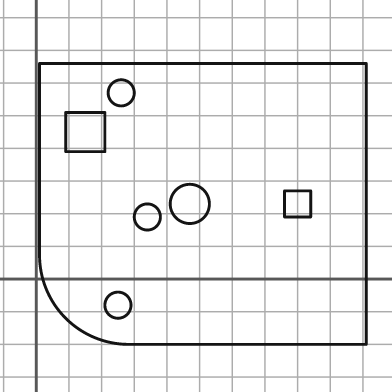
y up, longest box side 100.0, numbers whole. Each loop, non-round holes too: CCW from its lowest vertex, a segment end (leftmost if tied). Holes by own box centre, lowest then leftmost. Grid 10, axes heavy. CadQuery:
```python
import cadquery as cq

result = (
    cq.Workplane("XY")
    .moveTo(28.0, -20.0)
    .lineTo(101.0, -20.0)
    .lineTo(101.0, 66.0)
    .lineTo(1.0, 66.0)
    .lineTo(1.0, 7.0)
    .threePointArc((9.0, -12.0), (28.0, -20.0))
    .close()
    .moveTo(25.0, -8.0)
    .circle(4.0)
    .moveTo(34.0, 19.0)
    .circle(4.0)
    .moveTo(47.0, 23.0)
    .circle(6.0)
    .moveTo(76.0, 19.0)
    .lineTo(84.0, 19.0)
    .lineTo(84.0, 27.0)
    .lineTo(76.0, 27.0)
    .close()
    .moveTo(9.0, 39.0)
    .lineTo(21.0, 39.0)
    .lineTo(21.0, 51.0)
    .lineTo(9.0, 51.0)
    .close()
    .moveTo(26.0, 57.0)
    .circle(4.0)
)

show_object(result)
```